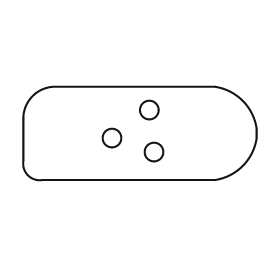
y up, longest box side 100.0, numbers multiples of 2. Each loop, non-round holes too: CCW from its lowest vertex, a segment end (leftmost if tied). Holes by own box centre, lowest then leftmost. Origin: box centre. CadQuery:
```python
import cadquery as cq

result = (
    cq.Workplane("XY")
    .moveTo(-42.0, -20.0)
    .lineTo(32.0, -20.0)
    .threePointArc((44.0, -14.0), (50.0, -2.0))
    .lineTo(50.0, 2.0)
    .threePointArc((44.0, 14.0), (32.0, 20.0))
    .lineTo(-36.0, 20.0)
    .threePointArc((-46.0, 16.0), (-50.0, 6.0))
    .lineTo(-50.0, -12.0)
    .threePointArc((-48.0, -18.0), (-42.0, -20.0))
    .close()
    .moveTo(6.0, -8.0)
    .circle(4.0)
    .moveTo(-12.0, -2.0)
    .circle(4.0)
    .moveTo(4.0, 10.0)
    .circle(4.0)
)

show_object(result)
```